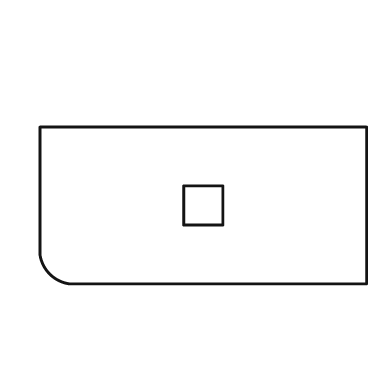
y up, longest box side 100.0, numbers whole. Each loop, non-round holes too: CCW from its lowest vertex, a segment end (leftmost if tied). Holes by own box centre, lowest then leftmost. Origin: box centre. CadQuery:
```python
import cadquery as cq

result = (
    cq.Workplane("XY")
    .moveTo(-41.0, -24.0)
    .lineTo(50.0, -24.0)
    .lineTo(50.0, 24.0)
    .lineTo(-50.0, 24.0)
    .lineTo(-50.0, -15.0)
    .threePointArc((-47.0, -21.0), (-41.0, -24.0))
    .close()
    .moveTo(-6.0, -6.0)
    .lineTo(6.0, -6.0)
    .lineTo(6.0, 6.0)
    .lineTo(-6.0, 6.0)
    .close()
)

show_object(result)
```